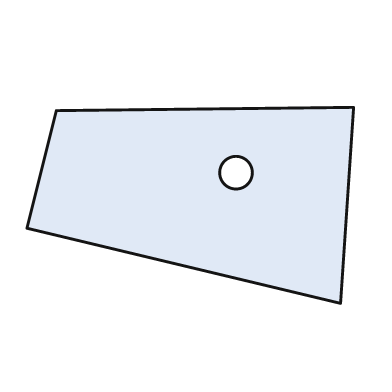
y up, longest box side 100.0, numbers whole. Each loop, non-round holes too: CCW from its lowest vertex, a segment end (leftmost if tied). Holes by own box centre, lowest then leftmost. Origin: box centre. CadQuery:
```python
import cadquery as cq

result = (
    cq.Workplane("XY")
    .moveTo(46.0, -30.0)
    .lineTo(50.0, 30.0)
    .lineTo(-41.0, 29.0)
    .lineTo(-50.0, -7.0)
    .close()
    .moveTo(14.0, 10.0)
    .circle(5.0)
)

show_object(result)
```